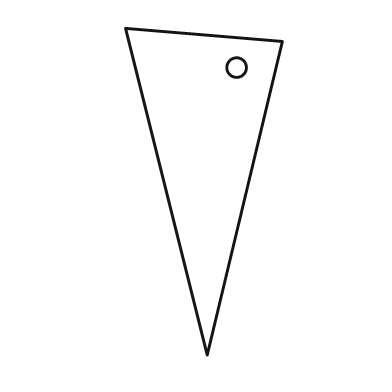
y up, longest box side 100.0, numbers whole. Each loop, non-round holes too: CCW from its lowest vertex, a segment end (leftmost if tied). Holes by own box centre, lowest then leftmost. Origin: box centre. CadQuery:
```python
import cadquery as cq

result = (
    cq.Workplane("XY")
    .moveTo(1.0, -50.0)
    .lineTo(24.0, 46.0)
    .lineTo(-24.0, 50.0)
    .close()
    .moveTo(10.0, 38.0)
    .circle(3.0)
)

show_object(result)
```